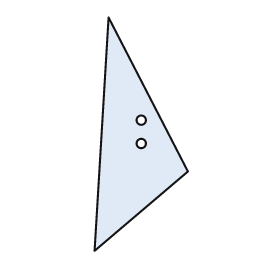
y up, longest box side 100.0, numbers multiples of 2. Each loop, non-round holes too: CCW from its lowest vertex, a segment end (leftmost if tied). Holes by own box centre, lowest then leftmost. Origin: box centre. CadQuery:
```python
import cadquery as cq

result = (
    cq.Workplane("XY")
    .moveTo(-20.0, -50.0)
    .lineTo(20.0, -16.0)
    .lineTo(-14.0, 50.0)
    .close()
    .moveTo(0.0, -4.0)
    .circle(2.0)
    .moveTo(0.0, 6.0)
    .circle(2.0)
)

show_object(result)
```